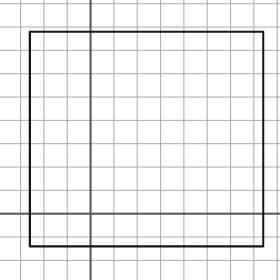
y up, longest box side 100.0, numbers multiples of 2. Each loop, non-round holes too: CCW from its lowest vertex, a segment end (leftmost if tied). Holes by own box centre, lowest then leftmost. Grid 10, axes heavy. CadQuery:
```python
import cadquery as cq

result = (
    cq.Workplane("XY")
    .moveTo(-26.0, -14.0)
    .lineTo(74.0, -14.0)
    .lineTo(74.0, 78.0)
    .lineTo(-26.0, 78.0)
    .close()
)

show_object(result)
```